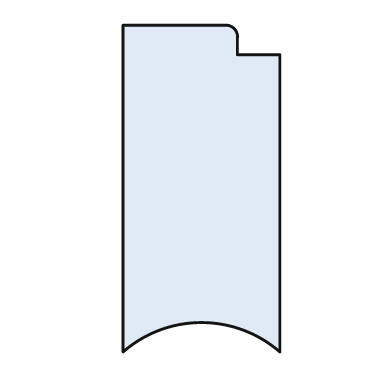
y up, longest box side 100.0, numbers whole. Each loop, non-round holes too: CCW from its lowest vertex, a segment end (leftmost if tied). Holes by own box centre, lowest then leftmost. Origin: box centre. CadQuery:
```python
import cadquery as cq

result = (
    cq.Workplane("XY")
    .moveTo(-24.0, -50.0)
    .threePointArc((0.0, -41.0), (24.0, -50.0))
    .lineTo(24.0, 41.0)
    .lineTo(11.0, 41.0)
    .lineTo(11.0, 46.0)
    .threePointArc((10.0, 49.0), (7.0, 50.0))
    .lineTo(-24.0, 50.0)
    .close()
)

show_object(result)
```